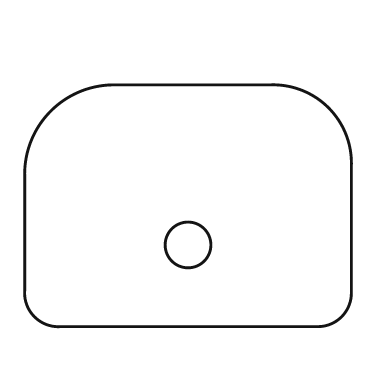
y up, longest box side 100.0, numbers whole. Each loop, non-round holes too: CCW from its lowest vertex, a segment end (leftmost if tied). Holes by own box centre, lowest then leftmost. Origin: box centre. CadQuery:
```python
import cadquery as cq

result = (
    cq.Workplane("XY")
    .moveTo(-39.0, -37.0)
    .lineTo(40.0, -37.0)
    .threePointArc((47.0, -34.0), (50.0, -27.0))
    .lineTo(50.0, 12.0)
    .threePointArc((43.0, 30.0), (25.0, 37.0))
    .lineTo(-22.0, 37.0)
    .threePointArc((-42.0, 29.0), (-50.0, 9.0))
    .lineTo(-50.0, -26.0)
    .threePointArc((-47.0, -34.0), (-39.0, -37.0))
    .close()
    .moveTo(0.0, -12.0)
    .circle(7.0)
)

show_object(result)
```